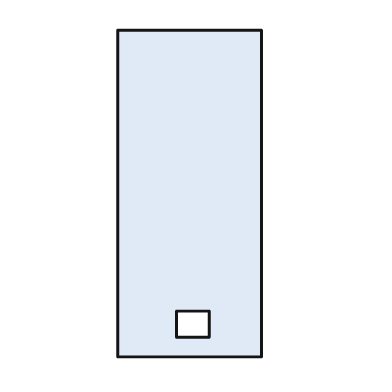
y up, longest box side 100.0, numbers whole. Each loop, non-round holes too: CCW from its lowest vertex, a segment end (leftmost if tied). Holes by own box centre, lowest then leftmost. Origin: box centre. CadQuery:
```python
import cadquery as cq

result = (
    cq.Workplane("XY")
    .moveTo(-22.0, -50.0)
    .lineTo(22.0, -50.0)
    .lineTo(22.0, 50.0)
    .lineTo(-22.0, 50.0)
    .close()
    .moveTo(-4.0, -44.0)
    .lineTo(6.0, -44.0)
    .lineTo(6.0, -36.0)
    .lineTo(-4.0, -36.0)
    .close()
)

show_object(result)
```